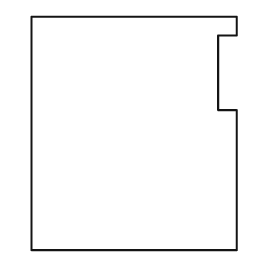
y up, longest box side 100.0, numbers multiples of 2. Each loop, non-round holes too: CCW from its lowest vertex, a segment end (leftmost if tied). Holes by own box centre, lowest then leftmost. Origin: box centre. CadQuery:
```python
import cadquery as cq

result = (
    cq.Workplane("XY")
    .moveTo(-44.0, -50.0)
    .lineTo(44.0, -50.0)
    .lineTo(44.0, 10.0)
    .lineTo(36.0, 10.0)
    .lineTo(36.0, 42.0)
    .lineTo(44.0, 42.0)
    .lineTo(44.0, 50.0)
    .lineTo(-44.0, 50.0)
    .close()
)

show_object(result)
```